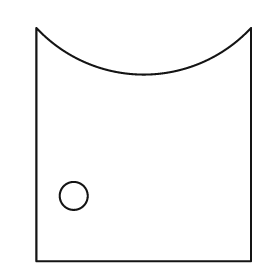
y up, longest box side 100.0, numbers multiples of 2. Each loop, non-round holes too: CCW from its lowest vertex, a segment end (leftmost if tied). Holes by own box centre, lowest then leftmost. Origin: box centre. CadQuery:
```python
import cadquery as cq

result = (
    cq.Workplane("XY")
    .moveTo(-46.0, -50.0)
    .lineTo(46.0, -50.0)
    .lineTo(46.0, 50.0)
    .threePointArc((0.0, 30.0), (-46.0, 50.0))
    .close()
    .moveTo(-30.0, -22.0)
    .circle(6.0)
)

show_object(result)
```